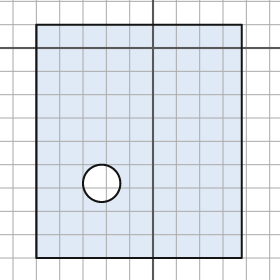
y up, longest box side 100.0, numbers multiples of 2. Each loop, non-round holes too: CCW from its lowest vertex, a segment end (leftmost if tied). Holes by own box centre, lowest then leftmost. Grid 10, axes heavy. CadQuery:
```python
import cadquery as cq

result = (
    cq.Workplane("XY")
    .moveTo(-50.0, -90.0)
    .lineTo(38.0, -90.0)
    .lineTo(38.0, 10.0)
    .lineTo(-50.0, 10.0)
    .close()
    .moveTo(-22.0, -58.0)
    .circle(8.0)
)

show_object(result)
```